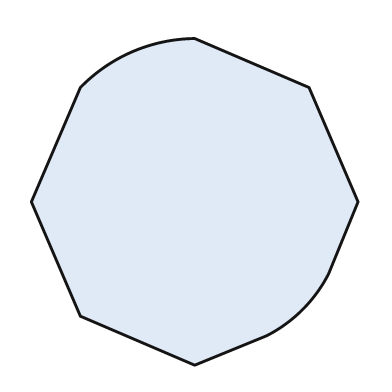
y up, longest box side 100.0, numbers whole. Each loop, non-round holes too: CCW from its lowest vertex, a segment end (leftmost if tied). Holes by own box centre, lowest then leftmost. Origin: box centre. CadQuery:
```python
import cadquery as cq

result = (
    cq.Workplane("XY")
    .moveTo(0.0, -50.0)
    .lineTo(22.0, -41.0)
    .threePointArc((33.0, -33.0), (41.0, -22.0))
    .lineTo(50.0, 0.0)
    .lineTo(35.0, 35.0)
    .lineTo(0.0, 50.0)
    .threePointArc((-19.0, 46.0), (-35.0, 35.0))
    .lineTo(-50.0, 0.0)
    .lineTo(-35.0, -35.0)
    .close()
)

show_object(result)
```